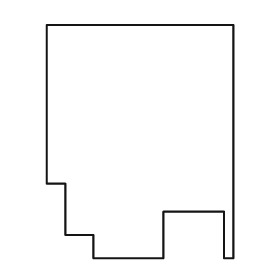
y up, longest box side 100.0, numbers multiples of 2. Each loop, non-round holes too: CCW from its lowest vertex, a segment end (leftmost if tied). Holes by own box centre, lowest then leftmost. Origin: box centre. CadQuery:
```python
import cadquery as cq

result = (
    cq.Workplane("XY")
    .moveTo(-20.0, -50.0)
    .lineTo(10.0, -50.0)
    .lineTo(10.0, -30.0)
    .lineTo(36.0, -30.0)
    .lineTo(36.0, -50.0)
    .lineTo(40.0, -50.0)
    .lineTo(40.0, 50.0)
    .lineTo(-40.0, 50.0)
    .lineTo(-40.0, -18.0)
    .lineTo(-32.0, -18.0)
    .lineTo(-32.0, -40.0)
    .lineTo(-20.0, -40.0)
    .close()
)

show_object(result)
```